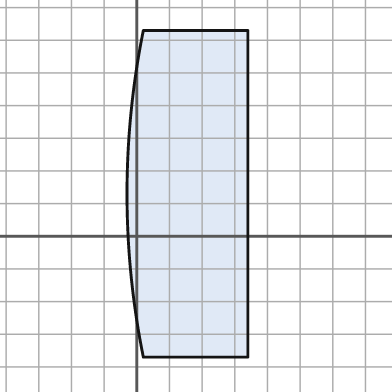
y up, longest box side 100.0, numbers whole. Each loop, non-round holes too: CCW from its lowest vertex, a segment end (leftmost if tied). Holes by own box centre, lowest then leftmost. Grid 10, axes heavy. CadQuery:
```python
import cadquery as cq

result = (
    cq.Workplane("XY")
    .moveTo(2.0, -37.0)
    .lineTo(34.0, -37.0)
    .lineTo(34.0, 63.0)
    .lineTo(2.0, 63.0)
    .threePointArc((-3.0, 13.0), (2.0, -37.0))
    .close()
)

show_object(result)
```